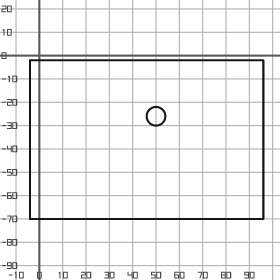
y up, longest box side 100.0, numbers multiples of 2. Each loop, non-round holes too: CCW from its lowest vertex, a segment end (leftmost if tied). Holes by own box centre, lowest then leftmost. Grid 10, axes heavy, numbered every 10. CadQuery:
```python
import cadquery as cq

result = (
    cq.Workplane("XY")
    .moveTo(-4.0, -70.0)
    .lineTo(96.0, -70.0)
    .lineTo(96.0, -2.0)
    .lineTo(-4.0, -2.0)
    .close()
    .moveTo(50.0, -26.0)
    .circle(4.0)
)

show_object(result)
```